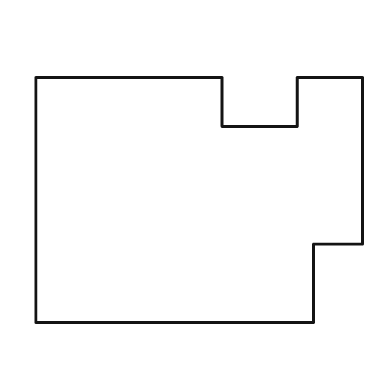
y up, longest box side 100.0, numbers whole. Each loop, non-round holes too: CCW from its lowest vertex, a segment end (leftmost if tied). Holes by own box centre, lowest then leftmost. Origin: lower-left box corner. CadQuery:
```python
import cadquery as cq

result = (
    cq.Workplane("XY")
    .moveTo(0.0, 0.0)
    .lineTo(85.0, 0.0)
    .lineTo(85.0, 24.0)
    .lineTo(100.0, 24.0)
    .lineTo(100.0, 75.0)
    .lineTo(80.0, 75.0)
    .lineTo(80.0, 60.0)
    .lineTo(57.0, 60.0)
    .lineTo(57.0, 75.0)
    .lineTo(0.0, 75.0)
    .close()
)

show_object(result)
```